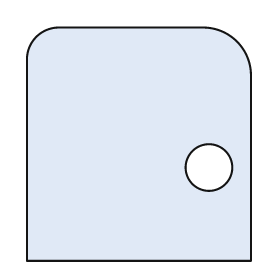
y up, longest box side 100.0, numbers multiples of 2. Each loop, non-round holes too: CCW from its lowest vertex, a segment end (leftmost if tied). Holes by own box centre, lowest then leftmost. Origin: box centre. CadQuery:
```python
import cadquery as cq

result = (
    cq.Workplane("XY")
    .moveTo(-48.0, -50.0)
    .lineTo(48.0, -50.0)
    .lineTo(48.0, 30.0)
    .threePointArc((42.0, 44.0), (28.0, 50.0))
    .lineTo(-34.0, 50.0)
    .threePointArc((-44.0, 46.0), (-48.0, 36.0))
    .close()
    .moveTo(30.0, -10.0)
    .circle(10.0)
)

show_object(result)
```